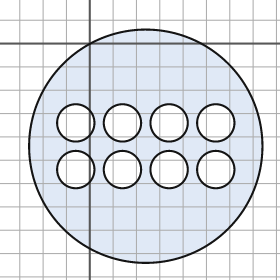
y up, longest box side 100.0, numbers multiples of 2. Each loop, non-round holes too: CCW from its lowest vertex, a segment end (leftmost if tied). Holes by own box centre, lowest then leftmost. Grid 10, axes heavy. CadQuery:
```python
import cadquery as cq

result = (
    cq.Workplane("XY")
    .moveTo(24.0, -44.0)
    .circle(50.0)
    .moveTo(-6.0, -54.0)
    .circle(8.0)
    .moveTo(14.0, -54.0)
    .circle(8.0)
    .moveTo(34.0, -54.0)
    .circle(8.0)
    .moveTo(54.0, -54.0)
    .circle(8.0)
    .moveTo(-6.0, -34.0)
    .circle(8.0)
    .moveTo(14.0, -34.0)
    .circle(8.0)
    .moveTo(34.0, -34.0)
    .circle(8.0)
    .moveTo(54.0, -34.0)
    .circle(8.0)
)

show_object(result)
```